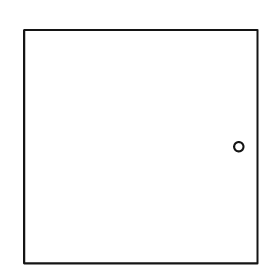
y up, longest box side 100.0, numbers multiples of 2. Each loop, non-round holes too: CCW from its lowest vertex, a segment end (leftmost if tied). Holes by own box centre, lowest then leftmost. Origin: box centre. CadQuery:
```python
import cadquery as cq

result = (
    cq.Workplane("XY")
    .moveTo(-50.0, -50.0)
    .lineTo(50.0, -50.0)
    .lineTo(50.0, 50.0)
    .lineTo(-50.0, 50.0)
    .close()
    .moveTo(42.0, 0.0)
    .circle(2.0)
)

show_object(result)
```